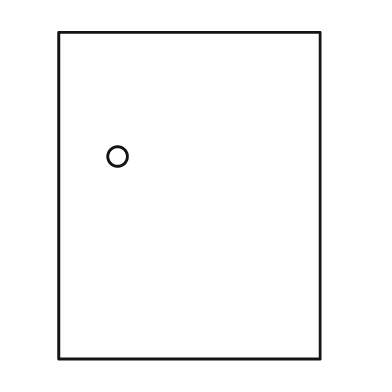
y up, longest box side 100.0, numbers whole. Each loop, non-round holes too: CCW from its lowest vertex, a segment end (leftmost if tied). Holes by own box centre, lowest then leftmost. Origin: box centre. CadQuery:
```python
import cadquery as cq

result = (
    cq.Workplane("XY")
    .moveTo(-40.0, -50.0)
    .lineTo(40.0, -50.0)
    .lineTo(40.0, 50.0)
    .lineTo(-40.0, 50.0)
    .close()
    .moveTo(-22.0, 12.0)
    .circle(3.0)
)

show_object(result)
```